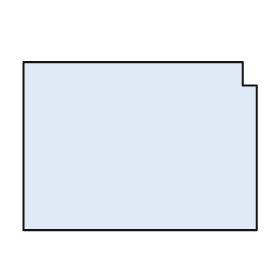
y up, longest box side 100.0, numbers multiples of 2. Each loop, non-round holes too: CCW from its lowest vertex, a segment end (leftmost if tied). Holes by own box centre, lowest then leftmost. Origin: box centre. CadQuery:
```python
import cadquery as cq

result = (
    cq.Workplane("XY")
    .moveTo(-50.0, -36.0)
    .lineTo(50.0, -36.0)
    .lineTo(50.0, 26.0)
    .lineTo(44.0, 26.0)
    .lineTo(44.0, 36.0)
    .lineTo(-50.0, 36.0)
    .close()
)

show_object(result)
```